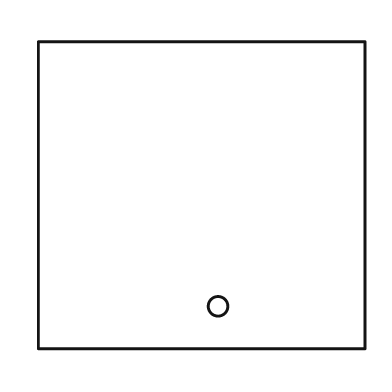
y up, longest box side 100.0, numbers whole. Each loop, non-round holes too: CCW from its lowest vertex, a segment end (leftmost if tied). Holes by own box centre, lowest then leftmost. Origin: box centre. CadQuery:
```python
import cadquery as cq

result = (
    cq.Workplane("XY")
    .moveTo(-50.0, -47.0)
    .lineTo(50.0, -47.0)
    .lineTo(50.0, 47.0)
    .lineTo(-50.0, 47.0)
    .close()
    .moveTo(5.0, -34.0)
    .circle(3.0)
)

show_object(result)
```